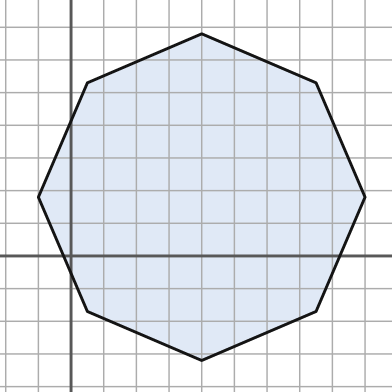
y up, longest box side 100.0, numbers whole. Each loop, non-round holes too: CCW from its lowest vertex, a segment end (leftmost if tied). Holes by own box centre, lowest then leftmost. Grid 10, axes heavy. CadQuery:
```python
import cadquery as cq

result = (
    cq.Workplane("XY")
    .moveTo(40.0, -32.0)
    .lineTo(75.0, -17.0)
    .lineTo(90.0, 18.0)
    .lineTo(75.0, 53.0)
    .lineTo(40.0, 68.0)
    .lineTo(5.0, 53.0)
    .lineTo(-10.0, 18.0)
    .lineTo(5.0, -17.0)
    .close()
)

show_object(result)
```